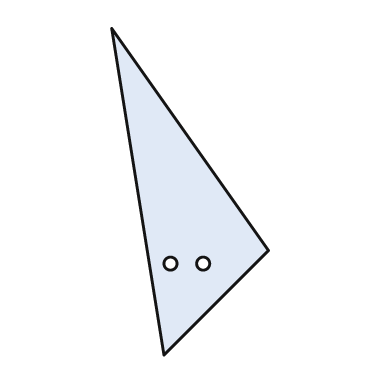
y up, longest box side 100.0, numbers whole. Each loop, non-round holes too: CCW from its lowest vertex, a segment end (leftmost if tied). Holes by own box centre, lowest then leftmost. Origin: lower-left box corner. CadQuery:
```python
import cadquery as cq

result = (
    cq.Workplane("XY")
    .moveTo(16.0, 0.0)
    .lineTo(48.0, 32.0)
    .lineTo(0.0, 100.0)
    .close()
    .moveTo(18.0, 28.0)
    .circle(2.0)
    .moveTo(28.0, 28.0)
    .circle(2.0)
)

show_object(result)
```